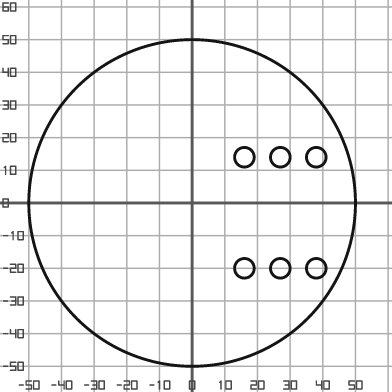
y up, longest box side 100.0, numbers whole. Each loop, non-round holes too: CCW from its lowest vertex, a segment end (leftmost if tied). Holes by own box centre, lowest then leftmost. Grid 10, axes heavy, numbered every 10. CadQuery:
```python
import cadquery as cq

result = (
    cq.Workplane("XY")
    .moveTo(0.0, 0.0)
    .circle(50.0)
    .moveTo(16.0, -20.0)
    .circle(3.0)
    .moveTo(27.0, -20.0)
    .circle(3.0)
    .moveTo(38.0, -20.0)
    .circle(3.0)
    .moveTo(16.0, 14.0)
    .circle(3.0)
    .moveTo(27.0, 14.0)
    .circle(3.0)
    .moveTo(38.0, 14.0)
    .circle(3.0)
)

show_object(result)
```